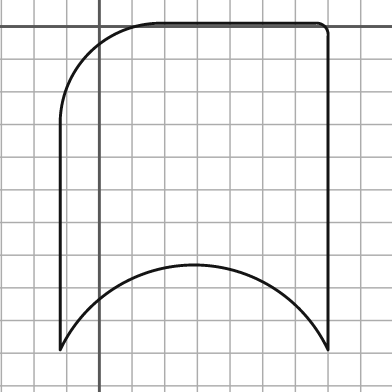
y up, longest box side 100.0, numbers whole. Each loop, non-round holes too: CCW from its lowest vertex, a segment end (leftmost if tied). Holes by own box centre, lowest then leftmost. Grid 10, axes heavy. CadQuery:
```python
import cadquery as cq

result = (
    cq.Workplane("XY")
    .moveTo(-12.0, -99.0)
    .threePointArc((29.0, -73.0), (70.0, -99.0))
    .lineTo(70.0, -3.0)
    .threePointArc((69.0, 0.0), (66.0, 1.0))
    .lineTo(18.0, 1.0)
    .threePointArc((-3.0, -8.0), (-12.0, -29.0))
    .close()
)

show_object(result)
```